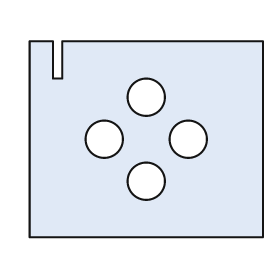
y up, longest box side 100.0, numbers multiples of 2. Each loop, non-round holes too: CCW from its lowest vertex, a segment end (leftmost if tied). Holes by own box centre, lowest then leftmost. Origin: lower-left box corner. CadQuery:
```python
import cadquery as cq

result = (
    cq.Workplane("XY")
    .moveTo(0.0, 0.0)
    .lineTo(100.0, 0.0)
    .lineTo(100.0, 84.0)
    .lineTo(14.0, 84.0)
    .lineTo(14.0, 68.0)
    .lineTo(10.0, 68.0)
    .lineTo(10.0, 84.0)
    .lineTo(0.0, 84.0)
    .close()
    .moveTo(50.0, 24.0)
    .circle(8.0)
    .moveTo(32.0, 42.0)
    .circle(8.0)
    .moveTo(68.0, 42.0)
    .circle(8.0)
    .moveTo(50.0, 60.0)
    .circle(8.0)
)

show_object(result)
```